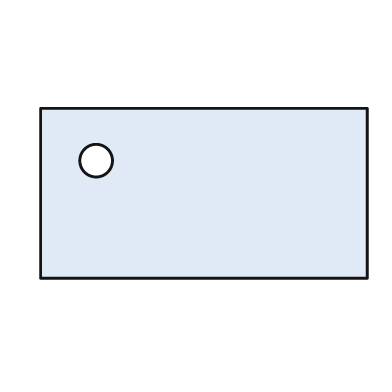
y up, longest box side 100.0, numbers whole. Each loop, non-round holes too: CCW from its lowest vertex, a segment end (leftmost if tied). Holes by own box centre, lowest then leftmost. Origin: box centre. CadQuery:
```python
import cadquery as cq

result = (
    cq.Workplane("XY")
    .moveTo(-50.0, -26.0)
    .lineTo(50.0, -26.0)
    .lineTo(50.0, 26.0)
    .lineTo(-50.0, 26.0)
    .close()
    .moveTo(-33.0, 10.0)
    .circle(5.0)
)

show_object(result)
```